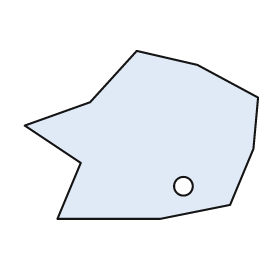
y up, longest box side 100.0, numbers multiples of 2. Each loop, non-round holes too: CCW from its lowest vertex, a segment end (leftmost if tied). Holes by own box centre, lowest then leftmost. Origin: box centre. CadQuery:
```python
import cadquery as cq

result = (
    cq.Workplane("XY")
    .moveTo(-36.0, -36.0)
    .lineTo(8.0, -36.0)
    .lineTo(38.0, -30.0)
    .lineTo(48.0, -6.0)
    .lineTo(50.0, 16.0)
    .lineTo(24.0, 30.0)
    .lineTo(-2.0, 36.0)
    .lineTo(-22.0, 14.0)
    .lineTo(-50.0, 4.0)
    .lineTo(-26.0, -12.0)
    .close()
    .moveTo(18.0, -22.0)
    .circle(4.0)
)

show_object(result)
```